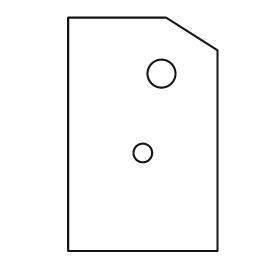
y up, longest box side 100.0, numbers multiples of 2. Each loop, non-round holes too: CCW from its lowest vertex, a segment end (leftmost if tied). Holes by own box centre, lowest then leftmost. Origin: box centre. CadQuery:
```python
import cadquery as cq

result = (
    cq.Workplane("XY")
    .moveTo(-32.0, -50.0)
    .lineTo(32.0, -50.0)
    .lineTo(32.0, 36.0)
    .lineTo(10.0, 50.0)
    .lineTo(-32.0, 50.0)
    .close()
    .moveTo(0.0, -8.0)
    .circle(4.0)
    .moveTo(8.0, 26.0)
    .circle(6.0)
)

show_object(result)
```